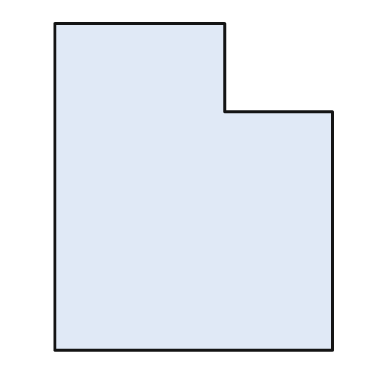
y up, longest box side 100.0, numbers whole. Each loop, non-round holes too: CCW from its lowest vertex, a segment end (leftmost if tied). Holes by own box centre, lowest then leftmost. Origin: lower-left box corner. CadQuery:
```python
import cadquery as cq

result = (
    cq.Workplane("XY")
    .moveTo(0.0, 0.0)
    .lineTo(85.0, 0.0)
    .lineTo(85.0, 73.0)
    .lineTo(52.0, 73.0)
    .lineTo(52.0, 100.0)
    .lineTo(0.0, 100.0)
    .close()
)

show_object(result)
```